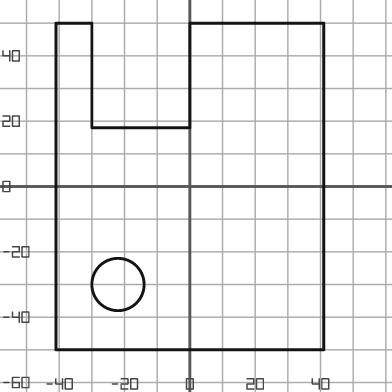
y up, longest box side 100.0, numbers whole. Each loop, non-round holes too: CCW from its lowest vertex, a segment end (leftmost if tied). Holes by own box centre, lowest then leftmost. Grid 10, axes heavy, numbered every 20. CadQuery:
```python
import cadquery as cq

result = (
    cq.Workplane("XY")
    .moveTo(-41.0, -50.0)
    .lineTo(41.0, -50.0)
    .lineTo(41.0, 50.0)
    .lineTo(0.0, 50.0)
    .lineTo(0.0, 18.0)
    .lineTo(-30.0, 18.0)
    .lineTo(-30.0, 50.0)
    .lineTo(-41.0, 50.0)
    .close()
    .moveTo(-22.0, -30.0)
    .circle(8.0)
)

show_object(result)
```